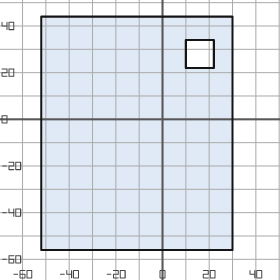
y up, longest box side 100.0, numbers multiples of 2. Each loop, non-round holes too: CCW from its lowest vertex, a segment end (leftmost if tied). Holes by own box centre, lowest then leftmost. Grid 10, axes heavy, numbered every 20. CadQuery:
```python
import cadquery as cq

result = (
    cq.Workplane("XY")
    .moveTo(-52.0, -56.0)
    .lineTo(30.0, -56.0)
    .lineTo(30.0, 44.0)
    .lineTo(-52.0, 44.0)
    .close()
    .moveTo(10.0, 22.0)
    .lineTo(22.0, 22.0)
    .lineTo(22.0, 34.0)
    .lineTo(10.0, 34.0)
    .close()
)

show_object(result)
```